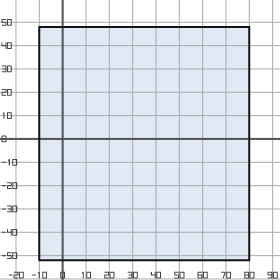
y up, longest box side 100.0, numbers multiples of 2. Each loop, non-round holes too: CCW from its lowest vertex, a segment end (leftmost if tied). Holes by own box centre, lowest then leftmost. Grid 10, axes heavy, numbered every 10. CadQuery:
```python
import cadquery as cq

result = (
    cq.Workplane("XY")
    .moveTo(-10.0, -52.0)
    .lineTo(80.0, -52.0)
    .lineTo(80.0, 48.0)
    .lineTo(-10.0, 48.0)
    .close()
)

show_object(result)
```